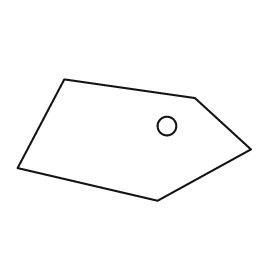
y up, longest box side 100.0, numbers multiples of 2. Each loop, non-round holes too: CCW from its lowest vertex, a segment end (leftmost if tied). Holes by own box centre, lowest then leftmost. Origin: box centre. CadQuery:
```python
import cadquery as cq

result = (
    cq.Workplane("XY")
    .moveTo(10.0, -26.0)
    .lineTo(50.0, -4.0)
    .lineTo(26.0, 18.0)
    .lineTo(-30.0, 26.0)
    .lineTo(-50.0, -12.0)
    .close()
    .moveTo(14.0, 6.0)
    .circle(4.0)
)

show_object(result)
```